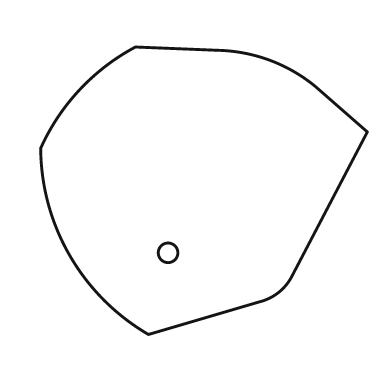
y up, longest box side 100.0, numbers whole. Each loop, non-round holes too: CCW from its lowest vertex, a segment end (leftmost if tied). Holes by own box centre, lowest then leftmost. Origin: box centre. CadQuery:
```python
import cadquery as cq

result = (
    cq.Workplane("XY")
    .moveTo(-17.0, -44.0)
    .lineTo(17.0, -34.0)
    .threePointArc((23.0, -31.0), (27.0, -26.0))
    .lineTo(50.0, 18.0)
    .lineTo(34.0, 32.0)
    .threePointArc((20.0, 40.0), (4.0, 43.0))
    .lineTo(-21.0, 44.0)
    .threePointArc((-38.0, 31.0), (-50.0, 13.0))
    .threePointArc((-41.0, -20.0), (-17.0, -44.0))
    .close()
    .moveTo(-11.0, -19.0)
    .circle(3.0)
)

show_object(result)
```